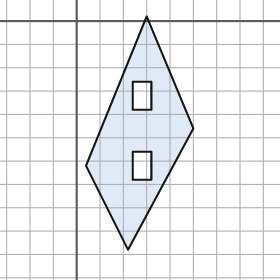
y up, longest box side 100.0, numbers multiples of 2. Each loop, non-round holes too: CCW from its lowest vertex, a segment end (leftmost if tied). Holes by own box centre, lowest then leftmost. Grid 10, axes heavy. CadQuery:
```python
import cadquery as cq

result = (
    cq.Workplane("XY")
    .moveTo(22.0, -98.0)
    .lineTo(50.0, -46.0)
    .lineTo(30.0, 2.0)
    .lineTo(4.0, -62.0)
    .close()
    .moveTo(24.0, -68.0)
    .lineTo(32.0, -68.0)
    .lineTo(32.0, -56.0)
    .lineTo(24.0, -56.0)
    .close()
    .moveTo(24.0, -38.0)
    .lineTo(32.0, -38.0)
    .lineTo(32.0, -26.0)
    .lineTo(24.0, -26.0)
    .close()
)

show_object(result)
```